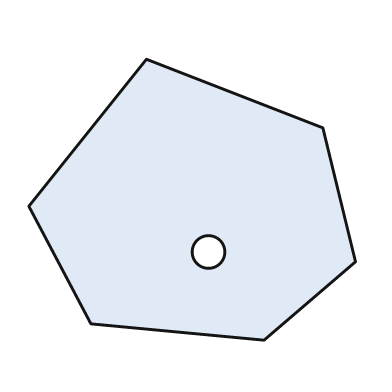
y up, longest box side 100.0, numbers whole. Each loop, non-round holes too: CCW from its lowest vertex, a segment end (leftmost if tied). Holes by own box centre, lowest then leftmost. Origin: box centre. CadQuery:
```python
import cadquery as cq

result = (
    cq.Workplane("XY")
    .moveTo(22.0, -43.0)
    .lineTo(50.0, -19.0)
    .lineTo(40.0, 22.0)
    .lineTo(-14.0, 43.0)
    .lineTo(-50.0, -2.0)
    .lineTo(-31.0, -38.0)
    .close()
    .moveTo(5.0, -16.0)
    .circle(5.0)
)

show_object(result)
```